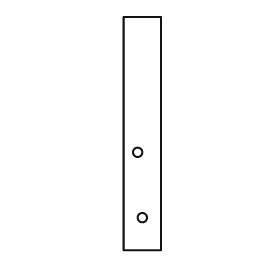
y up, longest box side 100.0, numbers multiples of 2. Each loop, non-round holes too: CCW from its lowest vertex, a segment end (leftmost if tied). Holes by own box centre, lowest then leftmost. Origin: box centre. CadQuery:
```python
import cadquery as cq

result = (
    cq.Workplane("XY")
    .moveTo(-8.0, -50.0)
    .lineTo(8.0, -50.0)
    .lineTo(8.0, 50.0)
    .lineTo(-8.0, 50.0)
    .close()
    .moveTo(0.0, -36.0)
    .circle(2.0)
    .moveTo(-2.0, -8.0)
    .circle(2.0)
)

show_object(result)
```